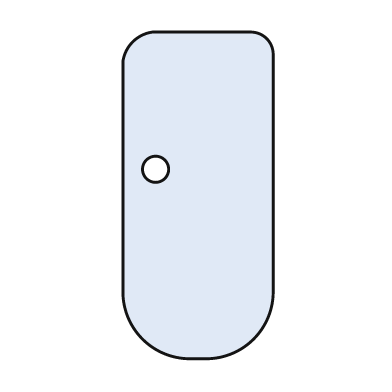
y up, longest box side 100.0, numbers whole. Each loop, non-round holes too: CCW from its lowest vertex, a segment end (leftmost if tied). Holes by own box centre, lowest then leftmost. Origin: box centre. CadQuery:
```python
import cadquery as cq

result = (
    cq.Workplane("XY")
    .moveTo(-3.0, -50.0)
    .lineTo(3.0, -50.0)
    .threePointArc((17.0, -44.0), (23.0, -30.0))
    .lineTo(23.0, 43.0)
    .threePointArc((21.0, 48.0), (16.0, 50.0))
    .lineTo(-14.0, 50.0)
    .threePointArc((-20.0, 47.0), (-23.0, 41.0))
    .lineTo(-23.0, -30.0)
    .threePointArc((-17.0, -44.0), (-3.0, -50.0))
    .close()
    .moveTo(-13.0, 8.0)
    .circle(4.0)
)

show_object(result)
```